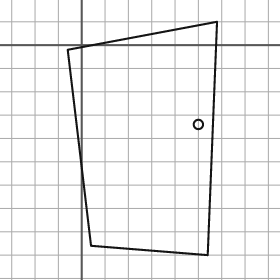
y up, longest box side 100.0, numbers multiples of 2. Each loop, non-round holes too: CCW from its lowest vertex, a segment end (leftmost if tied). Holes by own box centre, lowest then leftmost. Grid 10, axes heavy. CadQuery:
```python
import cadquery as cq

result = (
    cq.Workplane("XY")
    .moveTo(54.0, -90.0)
    .lineTo(58.0, 10.0)
    .lineTo(-6.0, -2.0)
    .lineTo(4.0, -86.0)
    .close()
    .moveTo(50.0, -34.0)
    .circle(2.0)
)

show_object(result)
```